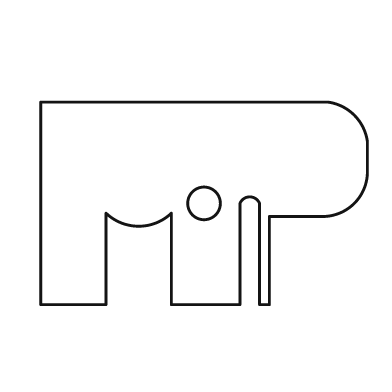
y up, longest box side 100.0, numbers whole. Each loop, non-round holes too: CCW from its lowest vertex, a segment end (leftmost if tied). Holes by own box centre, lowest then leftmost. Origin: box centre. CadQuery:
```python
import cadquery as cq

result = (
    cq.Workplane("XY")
    .moveTo(-50.0, -31.0)
    .lineTo(-30.0, -31.0)
    .lineTo(-30.0, -3.0)
    .threePointArc((-20.0, -7.0), (-10.0, -3.0))
    .lineTo(-10.0, -31.0)
    .lineTo(11.0, -31.0)
    .lineTo(11.0, 0.0)
    .threePointArc((14.0, 2.0), (17.0, 0.0))
    .lineTo(17.0, -31.0)
    .lineTo(20.0, -31.0)
    .lineTo(20.0, -4.0)
    .lineTo(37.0, -4.0)
    .threePointArc((46.0, 0.0), (50.0, 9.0))
    .lineTo(50.0, 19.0)
    .threePointArc((46.0, 27.0), (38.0, 31.0))
    .lineTo(-50.0, 31.0)
    .close()
    .moveTo(0.0, 0.0)
    .circle(5.0)
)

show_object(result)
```